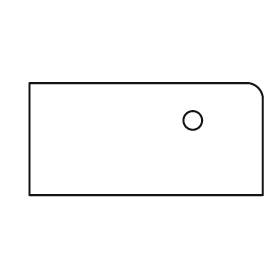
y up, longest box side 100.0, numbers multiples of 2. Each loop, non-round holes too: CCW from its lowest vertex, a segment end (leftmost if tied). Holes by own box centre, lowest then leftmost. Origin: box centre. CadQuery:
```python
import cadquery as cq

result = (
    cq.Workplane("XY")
    .moveTo(-50.0, -24.0)
    .lineTo(50.0, -24.0)
    .lineTo(50.0, 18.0)
    .threePointArc((48.0, 22.0), (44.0, 24.0))
    .lineTo(-50.0, 24.0)
    .close()
    .moveTo(20.0, 8.0)
    .circle(4.0)
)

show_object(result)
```